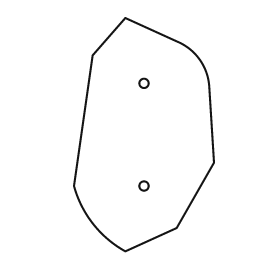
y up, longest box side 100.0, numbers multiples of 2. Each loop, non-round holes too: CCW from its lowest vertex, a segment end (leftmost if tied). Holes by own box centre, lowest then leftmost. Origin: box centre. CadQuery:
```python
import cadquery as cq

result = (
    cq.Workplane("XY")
    .moveTo(-8.0, -50.0)
    .lineTo(14.0, -40.0)
    .lineTo(30.0, -12.0)
    .lineTo(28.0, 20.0)
    .threePointArc((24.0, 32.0), (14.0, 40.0))
    .lineTo(-8.0, 50.0)
    .lineTo(-22.0, 34.0)
    .lineTo(-30.0, -22.0)
    .threePointArc((-22.0, -38.0), (-8.0, -50.0))
    .close()
    .moveTo(0.0, -22.0)
    .circle(2.0)
    .moveTo(0.0, 22.0)
    .circle(2.0)
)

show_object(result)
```